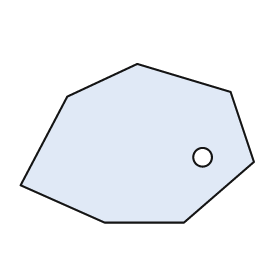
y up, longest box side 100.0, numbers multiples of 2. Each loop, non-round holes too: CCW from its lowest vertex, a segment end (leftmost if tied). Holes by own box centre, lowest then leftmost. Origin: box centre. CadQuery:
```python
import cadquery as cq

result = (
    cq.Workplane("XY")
    .moveTo(-14.0, -34.0)
    .lineTo(20.0, -34.0)
    .lineTo(50.0, -8.0)
    .lineTo(40.0, 22.0)
    .lineTo(0.0, 34.0)
    .lineTo(-30.0, 20.0)
    .lineTo(-50.0, -18.0)
    .close()
    .moveTo(28.0, -6.0)
    .circle(4.0)
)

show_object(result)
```